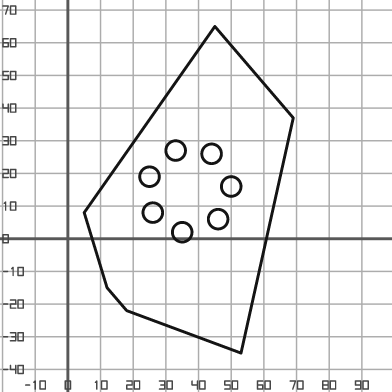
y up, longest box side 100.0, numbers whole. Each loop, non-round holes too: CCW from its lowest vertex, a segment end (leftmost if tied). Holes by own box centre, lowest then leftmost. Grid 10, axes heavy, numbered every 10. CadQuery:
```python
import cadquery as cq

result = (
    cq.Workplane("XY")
    .moveTo(53.0, -35.0)
    .lineTo(69.0, 37.0)
    .lineTo(45.0, 65.0)
    .lineTo(5.0, 8.0)
    .lineTo(12.0, -15.0)
    .lineTo(18.0, -22.0)
    .close()
    .moveTo(35.0, 2.0)
    .circle(3.0)
    .moveTo(46.0, 6.0)
    .circle(3.0)
    .moveTo(26.0, 8.0)
    .circle(3.0)
    .moveTo(50.0, 16.0)
    .circle(3.0)
    .moveTo(25.0, 19.0)
    .circle(3.0)
    .moveTo(44.0, 26.0)
    .circle(3.0)
    .moveTo(33.0, 27.0)
    .circle(3.0)
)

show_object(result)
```